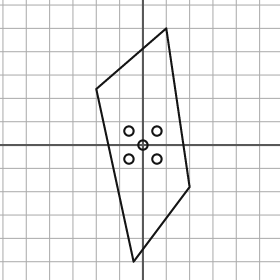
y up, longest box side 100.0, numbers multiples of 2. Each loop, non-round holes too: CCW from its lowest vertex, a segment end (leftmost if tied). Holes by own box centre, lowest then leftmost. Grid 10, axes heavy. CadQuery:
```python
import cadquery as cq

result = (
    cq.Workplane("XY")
    .moveTo(-4.0, -50.0)
    .lineTo(20.0, -18.0)
    .lineTo(10.0, 50.0)
    .lineTo(-20.0, 24.0)
    .close()
    .moveTo(-6.0, -6.0)
    .circle(2.0)
    .moveTo(6.0, -6.0)
    .circle(2.0)
    .moveTo(0.0, 0.0)
    .circle(2.0)
    .moveTo(-6.0, 6.0)
    .circle(2.0)
    .moveTo(6.0, 6.0)
    .circle(2.0)
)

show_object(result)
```